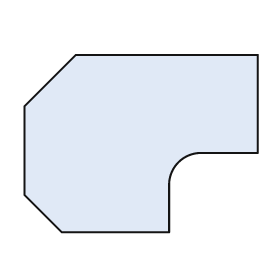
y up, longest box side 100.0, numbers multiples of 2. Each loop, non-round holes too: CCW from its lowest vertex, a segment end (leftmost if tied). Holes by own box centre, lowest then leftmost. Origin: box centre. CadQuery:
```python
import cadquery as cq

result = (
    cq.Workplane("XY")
    .moveTo(-34.0, -38.0)
    .lineTo(12.0, -38.0)
    .lineTo(12.0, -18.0)
    .threePointArc((16.0, -8.0), (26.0, -4.0))
    .lineTo(50.0, -4.0)
    .lineTo(50.0, 38.0)
    .lineTo(-28.0, 38.0)
    .lineTo(-50.0, 16.0)
    .lineTo(-50.0, -22.0)
    .close()
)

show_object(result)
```